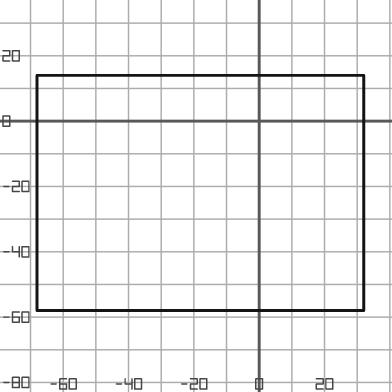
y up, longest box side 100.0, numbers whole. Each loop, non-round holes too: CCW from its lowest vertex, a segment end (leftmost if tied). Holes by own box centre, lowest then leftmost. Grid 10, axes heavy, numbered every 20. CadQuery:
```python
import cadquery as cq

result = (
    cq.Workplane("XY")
    .moveTo(-68.0, -58.0)
    .lineTo(32.0, -58.0)
    .lineTo(32.0, 14.0)
    .lineTo(-68.0, 14.0)
    .close()
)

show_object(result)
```